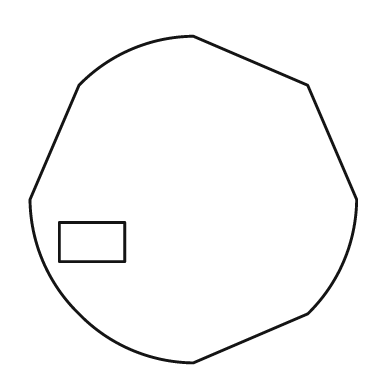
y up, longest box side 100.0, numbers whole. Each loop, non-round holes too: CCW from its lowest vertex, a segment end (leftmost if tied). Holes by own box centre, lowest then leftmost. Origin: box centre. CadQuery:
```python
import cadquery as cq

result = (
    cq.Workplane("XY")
    .moveTo(0.0, -50.0)
    .lineTo(35.0, -35.0)
    .threePointArc((46.0, -19.0), (50.0, 0.0))
    .lineTo(35.0, 35.0)
    .lineTo(0.0, 50.0)
    .threePointArc((-19.0, 46.0), (-35.0, 35.0))
    .lineTo(-50.0, 0.0)
    .threePointArc((-46.0, -19.0), (-35.0, -35.0))
    .threePointArc((-19.0, -46.0), (0.0, -50.0))
    .close()
    .moveTo(-41.0, -19.0)
    .lineTo(-21.0, -19.0)
    .lineTo(-21.0, -7.0)
    .lineTo(-41.0, -7.0)
    .close()
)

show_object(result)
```